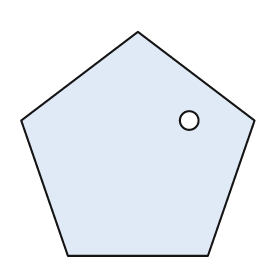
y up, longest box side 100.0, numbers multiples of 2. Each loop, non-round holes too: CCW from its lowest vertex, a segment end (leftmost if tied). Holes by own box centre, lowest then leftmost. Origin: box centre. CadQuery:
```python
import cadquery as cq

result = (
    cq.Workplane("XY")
    .moveTo(-30.0, -48.0)
    .lineTo(30.0, -48.0)
    .lineTo(50.0, 10.0)
    .lineTo(0.0, 48.0)
    .lineTo(-50.0, 10.0)
    .close()
    .moveTo(22.0, 10.0)
    .circle(4.0)
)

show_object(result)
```